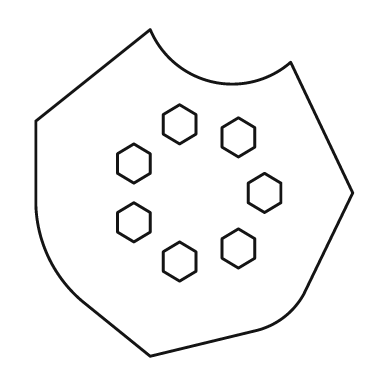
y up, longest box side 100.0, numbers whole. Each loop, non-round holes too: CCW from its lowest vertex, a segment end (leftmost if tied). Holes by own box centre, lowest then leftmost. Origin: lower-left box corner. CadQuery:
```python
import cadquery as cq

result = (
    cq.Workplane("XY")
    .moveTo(35.0, 0.0)
    .lineTo(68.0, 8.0)
    .threePointArc((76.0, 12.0), (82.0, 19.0))
    .lineTo(97.0, 50.0)
    .lineTo(78.0, 90.0)
    .threePointArc((54.0, 84.0), (35.0, 100.0))
    .lineTo(0.0, 72.0)
    .lineTo(0.0, 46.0)
    .threePointArc((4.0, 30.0), (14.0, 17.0))
    .close()
    .moveTo(44.0, 23.0)
    .lineTo(49.0, 26.0)
    .lineTo(49.0, 32.0)
    .lineTo(44.0, 35.0)
    .lineTo(39.0, 32.0)
    .lineTo(39.0, 26.0)
    .close()
    .moveTo(62.0, 27.0)
    .lineTo(67.0, 30.0)
    .lineTo(67.0, 36.0)
    .lineTo(62.0, 39.0)
    .lineTo(57.0, 36.0)
    .lineTo(57.0, 30.0)
    .close()
    .moveTo(30.0, 35.0)
    .lineTo(35.0, 38.0)
    .lineTo(35.0, 44.0)
    .lineTo(30.0, 47.0)
    .lineTo(25.0, 44.0)
    .lineTo(25.0, 38.0)
    .close()
    .moveTo(70.0, 44.0)
    .lineTo(75.0, 47.0)
    .lineTo(75.0, 53.0)
    .lineTo(70.0, 56.0)
    .lineTo(65.0, 53.0)
    .lineTo(65.0, 47.0)
    .close()
    .moveTo(30.0, 53.0)
    .lineTo(35.0, 56.0)
    .lineTo(35.0, 62.0)
    .lineTo(30.0, 65.0)
    .lineTo(25.0, 62.0)
    .lineTo(25.0, 56.0)
    .close()
    .moveTo(62.0, 61.0)
    .lineTo(67.0, 64.0)
    .lineTo(67.0, 70.0)
    .lineTo(62.0, 73.0)
    .lineTo(57.0, 70.0)
    .lineTo(57.0, 64.0)
    .close()
    .moveTo(44.0, 65.0)
    .lineTo(49.0, 68.0)
    .lineTo(49.0, 74.0)
    .lineTo(44.0, 77.0)
    .lineTo(39.0, 74.0)
    .lineTo(39.0, 68.0)
    .close()
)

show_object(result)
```